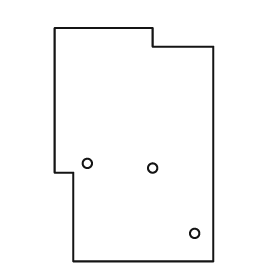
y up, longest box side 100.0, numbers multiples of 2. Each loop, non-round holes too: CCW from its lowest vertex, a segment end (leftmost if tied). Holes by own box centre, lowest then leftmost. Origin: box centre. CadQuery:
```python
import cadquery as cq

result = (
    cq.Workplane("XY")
    .moveTo(-26.0, -50.0)
    .lineTo(34.0, -50.0)
    .lineTo(34.0, 42.0)
    .lineTo(8.0, 42.0)
    .lineTo(8.0, 50.0)
    .lineTo(-34.0, 50.0)
    .lineTo(-34.0, -12.0)
    .lineTo(-26.0, -12.0)
    .close()
    .moveTo(26.0, -38.0)
    .circle(2.0)
    .moveTo(8.0, -10.0)
    .circle(2.0)
    .moveTo(-20.0, -8.0)
    .circle(2.0)
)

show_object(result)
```